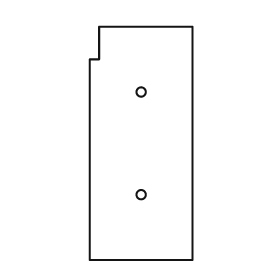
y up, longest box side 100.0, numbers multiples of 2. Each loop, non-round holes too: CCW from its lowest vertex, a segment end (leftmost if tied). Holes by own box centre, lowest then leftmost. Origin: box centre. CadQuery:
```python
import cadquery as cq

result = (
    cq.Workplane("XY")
    .moveTo(-22.0, -50.0)
    .lineTo(22.0, -50.0)
    .lineTo(22.0, 50.0)
    .lineTo(-18.0, 50.0)
    .lineTo(-18.0, 36.0)
    .lineTo(-22.0, 36.0)
    .close()
    .moveTo(0.0, -22.0)
    .circle(2.0)
    .moveTo(0.0, 22.0)
    .circle(2.0)
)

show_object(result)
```